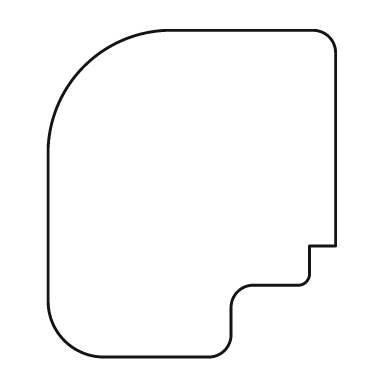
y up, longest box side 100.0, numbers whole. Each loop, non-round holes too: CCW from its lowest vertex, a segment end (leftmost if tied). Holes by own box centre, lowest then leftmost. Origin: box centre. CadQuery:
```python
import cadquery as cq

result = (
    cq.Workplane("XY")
    .moveTo(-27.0, -50.0)
    .lineTo(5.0, -50.0)
    .threePointArc((10.0, -48.0), (12.0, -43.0))
    .lineTo(12.0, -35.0)
    .threePointArc((14.0, -30.0), (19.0, -28.0))
    .lineTo(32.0, -28.0)
    .threePointArc((35.0, -27.0), (36.0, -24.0))
    .lineTo(36.0, -16.0)
    .lineTo(44.0, -16.0)
    .lineTo(44.0, 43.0)
    .threePointArc((42.0, 48.0), (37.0, 50.0))
    .lineTo(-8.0, 50.0)
    .threePointArc((-33.0, 39.0), (-44.0, 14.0))
    .lineTo(-44.0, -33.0)
    .threePointArc((-39.0, -45.0), (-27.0, -50.0))
    .close()
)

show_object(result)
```